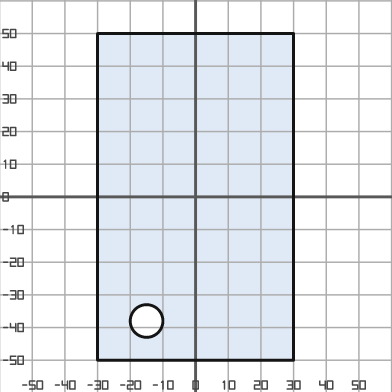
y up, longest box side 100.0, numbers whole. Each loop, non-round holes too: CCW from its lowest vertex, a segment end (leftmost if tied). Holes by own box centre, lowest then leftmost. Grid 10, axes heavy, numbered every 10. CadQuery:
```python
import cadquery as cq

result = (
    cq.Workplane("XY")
    .moveTo(-30.0, -50.0)
    .lineTo(30.0, -50.0)
    .lineTo(30.0, 50.0)
    .lineTo(-30.0, 50.0)
    .close()
    .moveTo(-15.0, -38.0)
    .circle(5.0)
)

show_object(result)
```